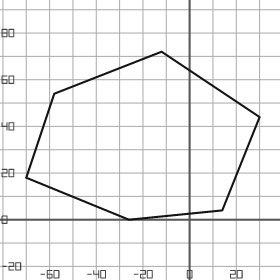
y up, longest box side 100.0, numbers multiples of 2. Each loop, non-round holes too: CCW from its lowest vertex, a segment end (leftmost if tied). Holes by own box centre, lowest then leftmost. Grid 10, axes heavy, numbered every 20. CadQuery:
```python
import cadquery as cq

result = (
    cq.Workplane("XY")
    .moveTo(-26.0, 0.0)
    .lineTo(14.0, 4.0)
    .lineTo(30.0, 44.0)
    .lineTo(-12.0, 72.0)
    .lineTo(-58.0, 54.0)
    .lineTo(-70.0, 18.0)
    .close()
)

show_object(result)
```